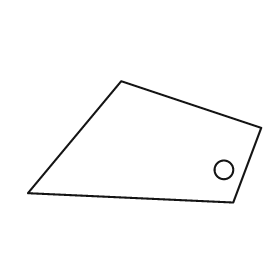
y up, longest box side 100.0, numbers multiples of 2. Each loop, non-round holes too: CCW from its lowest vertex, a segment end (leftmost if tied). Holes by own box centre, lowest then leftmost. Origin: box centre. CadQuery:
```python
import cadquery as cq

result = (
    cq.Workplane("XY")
    .moveTo(38.0, -26.0)
    .lineTo(50.0, 6.0)
    .lineTo(-10.0, 26.0)
    .lineTo(-50.0, -22.0)
    .close()
    .moveTo(34.0, -12.0)
    .circle(4.0)
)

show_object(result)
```